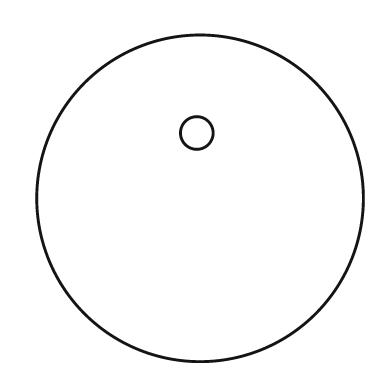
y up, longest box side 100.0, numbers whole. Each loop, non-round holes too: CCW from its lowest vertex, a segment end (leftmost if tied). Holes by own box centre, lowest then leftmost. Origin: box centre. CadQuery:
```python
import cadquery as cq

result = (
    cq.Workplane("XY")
    .moveTo(0.0, 0.0)
    .circle(50.0)
    .moveTo(-1.0, 20.0)
    .circle(5.0)
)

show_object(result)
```